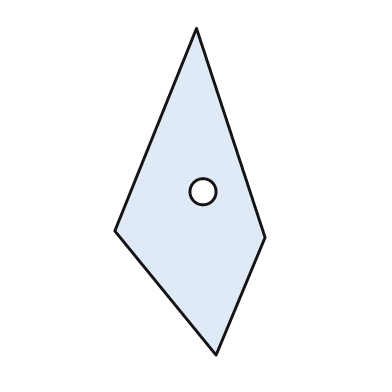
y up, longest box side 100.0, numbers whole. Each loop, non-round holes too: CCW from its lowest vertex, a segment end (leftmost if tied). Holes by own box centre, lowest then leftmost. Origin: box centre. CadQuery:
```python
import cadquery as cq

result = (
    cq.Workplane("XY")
    .moveTo(8.0, -50.0)
    .lineTo(23.0, -14.0)
    .lineTo(2.0, 50.0)
    .lineTo(-23.0, -12.0)
    .close()
    .moveTo(4.0, 0.0)
    .circle(4.0)
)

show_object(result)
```